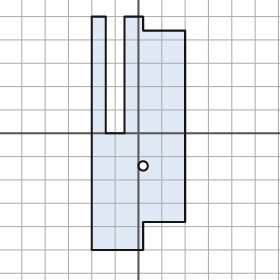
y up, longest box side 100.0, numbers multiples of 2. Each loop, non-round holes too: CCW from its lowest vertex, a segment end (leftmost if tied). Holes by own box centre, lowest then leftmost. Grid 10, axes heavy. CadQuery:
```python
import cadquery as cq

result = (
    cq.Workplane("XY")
    .moveTo(-20.0, -50.0)
    .lineTo(2.0, -50.0)
    .lineTo(2.0, -38.0)
    .lineTo(20.0, -38.0)
    .lineTo(20.0, 44.0)
    .lineTo(2.0, 44.0)
    .lineTo(2.0, 50.0)
    .lineTo(-6.0, 50.0)
    .lineTo(-6.0, 0.0)
    .lineTo(-14.0, 0.0)
    .lineTo(-14.0, 50.0)
    .lineTo(-20.0, 50.0)
    .close()
    .moveTo(2.0, -14.0)
    .circle(2.0)
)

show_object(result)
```